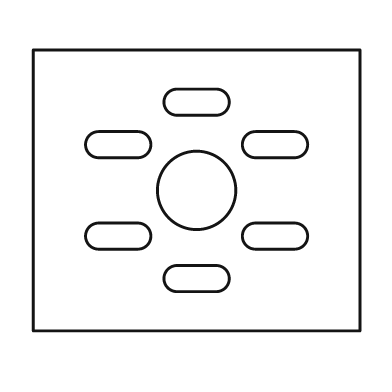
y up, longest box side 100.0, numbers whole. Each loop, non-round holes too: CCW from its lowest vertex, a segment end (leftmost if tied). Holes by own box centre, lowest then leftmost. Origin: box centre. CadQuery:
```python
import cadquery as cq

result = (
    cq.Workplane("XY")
    .moveTo(-50.0, -43.0)
    .lineTo(50.0, -43.0)
    .lineTo(50.0, 43.0)
    .lineTo(-50.0, 43.0)
    .close()
    .moveTo(-6.0, -31.0)
    .lineTo(6.0, -31.0)
    .threePointArc((10.0, -27.0), (6.0, -23.0))
    .lineTo(-6.0, -23.0)
    .threePointArc((-10.0, -27.0), (-6.0, -31.0))
    .close()
    .moveTo(-30.0, -18.0)
    .lineTo(-18.0, -18.0)
    .threePointArc((-14.0, -14.0), (-18.0, -10.0))
    .lineTo(-30.0, -10.0)
    .threePointArc((-34.0, -14.0), (-30.0, -18.0))
    .close()
    .moveTo(18.0, -18.0)
    .lineTo(30.0, -18.0)
    .threePointArc((34.0, -14.0), (30.0, -10.0))
    .lineTo(18.0, -10.0)
    .threePointArc((14.0, -14.0), (18.0, -18.0))
    .close()
    .moveTo(0.0, 0.0)
    .circle(12.0)
    .moveTo(-30.0, 10.0)
    .lineTo(-18.0, 10.0)
    .threePointArc((-14.0, 14.0), (-18.0, 18.0))
    .lineTo(-30.0, 18.0)
    .threePointArc((-34.0, 14.0), (-30.0, 10.0))
    .close()
    .moveTo(18.0, 10.0)
    .lineTo(30.0, 10.0)
    .threePointArc((34.0, 14.0), (30.0, 18.0))
    .lineTo(18.0, 18.0)
    .threePointArc((14.0, 14.0), (18.0, 10.0))
    .close()
    .moveTo(-6.0, 23.0)
    .lineTo(6.0, 23.0)
    .threePointArc((10.0, 27.0), (6.0, 31.0))
    .lineTo(-6.0, 31.0)
    .threePointArc((-10.0, 27.0), (-6.0, 23.0))
    .close()
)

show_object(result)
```